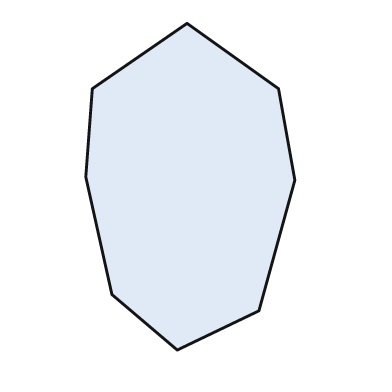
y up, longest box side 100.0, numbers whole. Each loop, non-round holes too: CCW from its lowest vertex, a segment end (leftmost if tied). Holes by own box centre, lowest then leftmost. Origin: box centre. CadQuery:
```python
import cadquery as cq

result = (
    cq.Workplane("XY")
    .moveTo(-4.0, -50.0)
    .lineTo(21.0, -38.0)
    .lineTo(32.0, 2.0)
    .lineTo(27.0, 30.0)
    .lineTo(-1.0, 50.0)
    .lineTo(-30.0, 30.0)
    .lineTo(-32.0, 3.0)
    .lineTo(-24.0, -33.0)
    .close()
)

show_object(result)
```